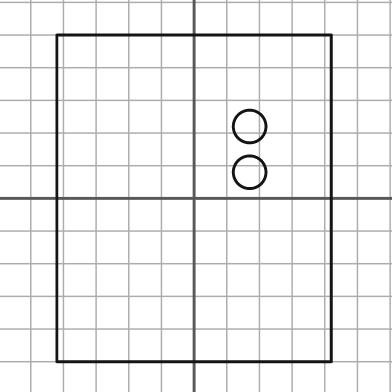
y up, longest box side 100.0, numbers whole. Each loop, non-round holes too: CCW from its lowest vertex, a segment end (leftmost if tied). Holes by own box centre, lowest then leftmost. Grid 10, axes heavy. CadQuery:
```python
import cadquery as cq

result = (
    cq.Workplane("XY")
    .moveTo(-42.0, -50.0)
    .lineTo(42.0, -50.0)
    .lineTo(42.0, 50.0)
    .lineTo(-42.0, 50.0)
    .close()
    .moveTo(17.0, 8.0)
    .circle(5.0)
    .moveTo(17.0, 22.0)
    .circle(5.0)
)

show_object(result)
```